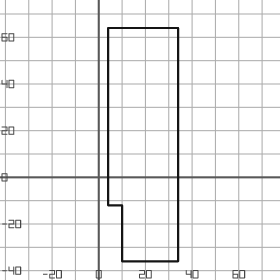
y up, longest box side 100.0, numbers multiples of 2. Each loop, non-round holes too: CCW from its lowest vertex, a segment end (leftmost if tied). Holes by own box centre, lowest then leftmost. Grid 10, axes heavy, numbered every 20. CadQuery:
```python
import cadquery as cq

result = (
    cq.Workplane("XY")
    .moveTo(10.0, -36.0)
    .lineTo(34.0, -36.0)
    .lineTo(34.0, 64.0)
    .lineTo(4.0, 64.0)
    .lineTo(4.0, -12.0)
    .lineTo(10.0, -12.0)
    .close()
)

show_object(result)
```